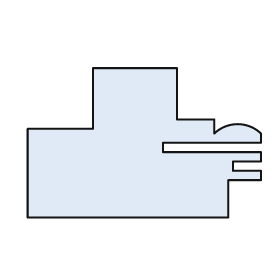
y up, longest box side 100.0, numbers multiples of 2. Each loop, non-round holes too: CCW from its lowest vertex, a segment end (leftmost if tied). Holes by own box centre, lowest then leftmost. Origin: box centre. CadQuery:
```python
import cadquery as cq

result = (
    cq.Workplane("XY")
    .moveTo(-50.0, -32.0)
    .lineTo(36.0, -32.0)
    .lineTo(36.0, -16.0)
    .lineTo(50.0, -16.0)
    .lineTo(50.0, -12.0)
    .lineTo(38.0, -12.0)
    .lineTo(38.0, -8.0)
    .lineTo(50.0, -8.0)
    .lineTo(50.0, -4.0)
    .lineTo(8.0, -4.0)
    .lineTo(8.0, 0.0)
    .lineTo(50.0, 0.0)
    .lineTo(50.0, 4.0)
    .threePointArc((40.0, 8.0), (30.0, 4.0))
    .lineTo(30.0, 10.0)
    .lineTo(14.0, 10.0)
    .lineTo(14.0, 32.0)
    .lineTo(-22.0, 32.0)
    .lineTo(-22.0, 6.0)
    .lineTo(-50.0, 6.0)
    .close()
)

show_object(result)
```